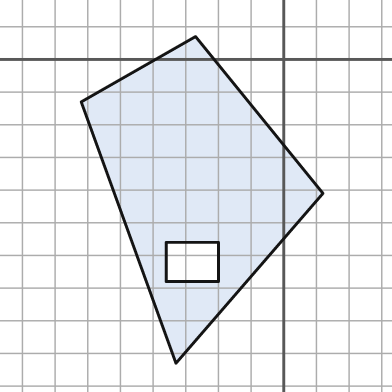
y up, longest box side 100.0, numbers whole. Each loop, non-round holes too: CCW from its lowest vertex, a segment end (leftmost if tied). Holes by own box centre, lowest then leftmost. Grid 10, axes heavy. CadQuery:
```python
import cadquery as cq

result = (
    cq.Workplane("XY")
    .moveTo(-33.0, -93.0)
    .lineTo(12.0, -41.0)
    .lineTo(-27.0, 7.0)
    .lineTo(-62.0, -13.0)
    .close()
    .moveTo(-36.0, -68.0)
    .lineTo(-20.0, -68.0)
    .lineTo(-20.0, -56.0)
    .lineTo(-36.0, -56.0)
    .close()
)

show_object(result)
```